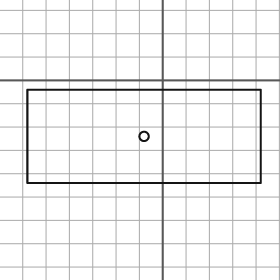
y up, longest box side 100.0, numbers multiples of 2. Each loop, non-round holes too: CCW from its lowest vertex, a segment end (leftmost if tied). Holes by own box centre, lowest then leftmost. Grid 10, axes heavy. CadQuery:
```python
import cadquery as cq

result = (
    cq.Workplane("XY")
    .moveTo(-58.0, -44.0)
    .lineTo(42.0, -44.0)
    .lineTo(42.0, -4.0)
    .lineTo(-58.0, -4.0)
    .close()
    .moveTo(-8.0, -24.0)
    .circle(2.0)
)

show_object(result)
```